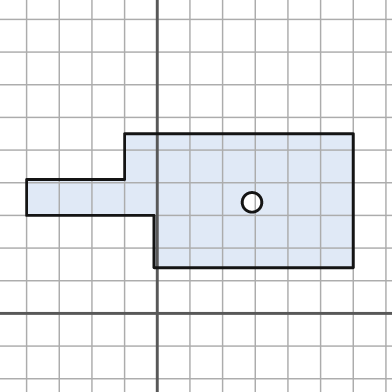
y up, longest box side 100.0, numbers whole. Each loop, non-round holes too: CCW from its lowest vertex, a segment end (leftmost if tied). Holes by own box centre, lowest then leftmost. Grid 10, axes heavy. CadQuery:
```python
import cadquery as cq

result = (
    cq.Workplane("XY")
    .moveTo(-1.0, 14.0)
    .lineTo(60.0, 14.0)
    .lineTo(60.0, 55.0)
    .lineTo(-10.0, 55.0)
    .lineTo(-10.0, 41.0)
    .lineTo(-40.0, 41.0)
    .lineTo(-40.0, 30.0)
    .lineTo(-1.0, 30.0)
    .close()
    .moveTo(29.0, 34.0)
    .circle(3.0)
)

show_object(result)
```